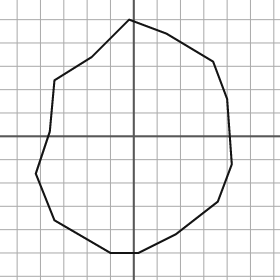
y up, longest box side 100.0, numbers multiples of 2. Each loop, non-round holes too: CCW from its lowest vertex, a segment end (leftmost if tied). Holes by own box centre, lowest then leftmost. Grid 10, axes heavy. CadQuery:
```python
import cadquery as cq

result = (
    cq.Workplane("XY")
    .moveTo(-10.0, -50.0)
    .lineTo(2.0, -50.0)
    .lineTo(18.0, -42.0)
    .lineTo(36.0, -28.0)
    .lineTo(42.0, -12.0)
    .lineTo(40.0, 16.0)
    .lineTo(34.0, 32.0)
    .lineTo(14.0, 44.0)
    .lineTo(-2.0, 50.0)
    .lineTo(-18.0, 34.0)
    .lineTo(-34.0, 24.0)
    .lineTo(-36.0, 2.0)
    .lineTo(-42.0, -16.0)
    .lineTo(-34.0, -36.0)
    .close()
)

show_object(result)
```